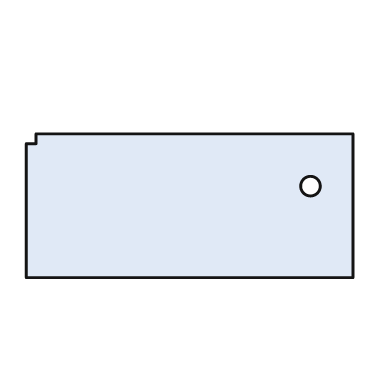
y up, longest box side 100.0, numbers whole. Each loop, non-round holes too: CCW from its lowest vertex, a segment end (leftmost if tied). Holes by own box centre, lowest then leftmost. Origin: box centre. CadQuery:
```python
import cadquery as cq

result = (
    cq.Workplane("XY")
    .moveTo(-50.0, -22.0)
    .lineTo(50.0, -22.0)
    .lineTo(50.0, 22.0)
    .lineTo(-47.0, 22.0)
    .lineTo(-47.0, 19.0)
    .lineTo(-50.0, 19.0)
    .close()
    .moveTo(37.0, 6.0)
    .circle(3.0)
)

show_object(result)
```